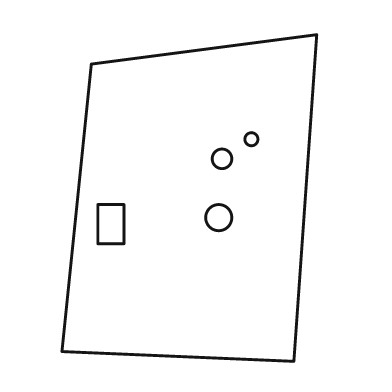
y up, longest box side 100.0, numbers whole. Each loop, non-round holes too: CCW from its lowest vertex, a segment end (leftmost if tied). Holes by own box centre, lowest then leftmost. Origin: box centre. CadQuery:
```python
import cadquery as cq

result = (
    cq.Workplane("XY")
    .moveTo(32.0, -50.0)
    .lineTo(39.0, 50.0)
    .lineTo(-30.0, 41.0)
    .lineTo(-39.0, -47.0)
    .close()
    .moveTo(-28.0, -14.0)
    .lineTo(-20.0, -14.0)
    .lineTo(-20.0, -2.0)
    .lineTo(-28.0, -2.0)
    .close()
    .moveTo(9.0, -6.0)
    .circle(4.0)
    .moveTo(10.0, 12.0)
    .circle(3.0)
    .moveTo(19.0, 18.0)
    .circle(2.0)
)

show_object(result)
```